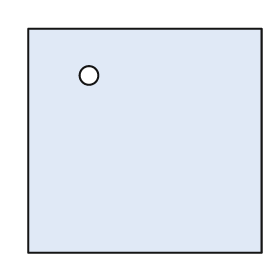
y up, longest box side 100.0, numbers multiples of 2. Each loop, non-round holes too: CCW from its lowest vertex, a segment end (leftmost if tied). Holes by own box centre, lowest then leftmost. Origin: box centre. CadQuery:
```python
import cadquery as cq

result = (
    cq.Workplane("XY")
    .moveTo(-50.0, -48.0)
    .lineTo(50.0, -48.0)
    .lineTo(50.0, 48.0)
    .lineTo(-50.0, 48.0)
    .close()
    .moveTo(-24.0, 28.0)
    .circle(4.0)
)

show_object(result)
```